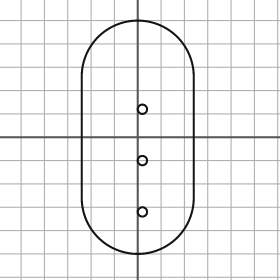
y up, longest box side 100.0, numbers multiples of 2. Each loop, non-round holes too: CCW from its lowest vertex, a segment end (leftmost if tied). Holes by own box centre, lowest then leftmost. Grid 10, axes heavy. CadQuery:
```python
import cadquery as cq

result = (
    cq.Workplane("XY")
    .moveTo(-24.0, -26.0)
    .threePointArc((0.0, -50.0), (24.0, -26.0))
    .lineTo(24.0, 26.0)
    .threePointArc((0.0, 50.0), (-24.0, 26.0))
    .close()
    .moveTo(2.0, -32.0)
    .circle(2.0)
    .moveTo(2.0, -10.0)
    .circle(2.0)
    .moveTo(2.0, 12.0)
    .circle(2.0)
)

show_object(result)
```